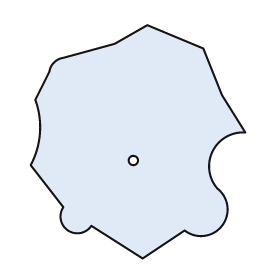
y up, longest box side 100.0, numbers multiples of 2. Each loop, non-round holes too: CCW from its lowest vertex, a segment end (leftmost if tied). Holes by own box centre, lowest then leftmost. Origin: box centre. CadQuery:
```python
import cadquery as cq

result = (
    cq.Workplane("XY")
    .moveTo(2.0, -50.0)
    .lineTo(20.0, -38.0)
    .threePointArc((36.0, -36.0), (34.0, -20.0))
    .threePointArc((32.0, -4.0), (46.0, 4.0))
    .lineTo(36.0, 20.0)
    .lineTo(28.0, 40.0)
    .lineTo(4.0, 50.0)
    .lineTo(-10.0, 42.0)
    .lineTo(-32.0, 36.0)
    .threePointArc((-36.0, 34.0), (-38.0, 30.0))
    .lineTo(-44.0, 18.0)
    .threePointArc((-42.0, 4.0), (-46.0, -10.0))
    .lineTo(-32.0, -28.0)
    .threePointArc((-30.0, -38.0), (-20.0, -36.0))
    .close()
    .moveTo(-2.0, -8.0)
    .circle(2.0)
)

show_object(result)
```